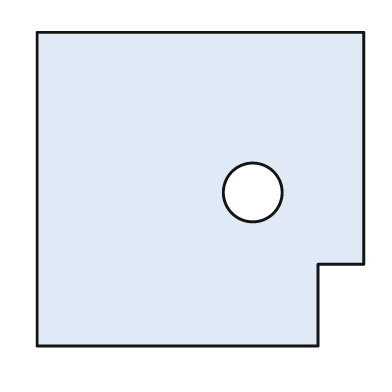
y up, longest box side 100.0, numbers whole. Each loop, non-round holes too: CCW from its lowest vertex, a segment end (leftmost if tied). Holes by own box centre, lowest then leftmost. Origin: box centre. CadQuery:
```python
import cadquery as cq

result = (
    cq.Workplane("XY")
    .moveTo(-50.0, -48.0)
    .lineTo(36.0, -48.0)
    .lineTo(36.0, -23.0)
    .lineTo(50.0, -23.0)
    .lineTo(50.0, 48.0)
    .lineTo(-50.0, 48.0)
    .close()
    .moveTo(16.0, -1.0)
    .circle(9.0)
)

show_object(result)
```